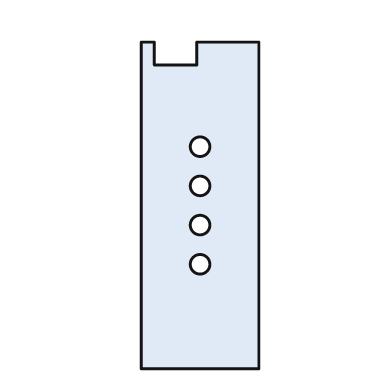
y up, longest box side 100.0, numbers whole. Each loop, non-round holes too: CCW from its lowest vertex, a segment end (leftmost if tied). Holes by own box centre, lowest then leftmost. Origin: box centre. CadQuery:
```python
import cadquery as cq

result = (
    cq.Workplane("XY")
    .moveTo(-18.0, -50.0)
    .lineTo(18.0, -50.0)
    .lineTo(18.0, 50.0)
    .lineTo(-1.0, 50.0)
    .lineTo(-1.0, 43.0)
    .lineTo(-14.0, 43.0)
    .lineTo(-14.0, 50.0)
    .lineTo(-18.0, 50.0)
    .close()
    .moveTo(0.0, -18.0)
    .circle(3.0)
    .moveTo(0.0, -6.0)
    .circle(3.0)
    .moveTo(0.0, 6.0)
    .circle(3.0)
    .moveTo(0.0, 18.0)
    .circle(3.0)
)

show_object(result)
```